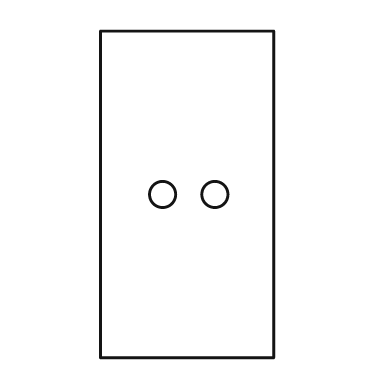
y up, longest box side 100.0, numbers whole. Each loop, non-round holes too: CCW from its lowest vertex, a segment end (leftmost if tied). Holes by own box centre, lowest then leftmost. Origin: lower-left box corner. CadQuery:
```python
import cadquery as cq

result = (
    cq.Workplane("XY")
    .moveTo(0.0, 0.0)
    .lineTo(53.0, 0.0)
    .lineTo(53.0, 100.0)
    .lineTo(0.0, 100.0)
    .close()
    .moveTo(19.0, 50.0)
    .circle(4.0)
    .moveTo(35.0, 50.0)
    .circle(4.0)
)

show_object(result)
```